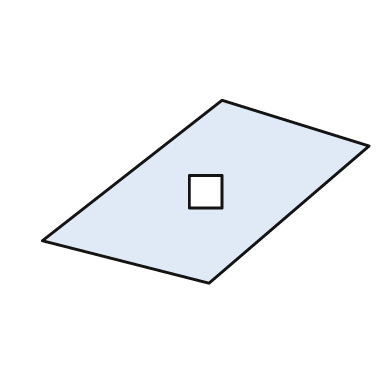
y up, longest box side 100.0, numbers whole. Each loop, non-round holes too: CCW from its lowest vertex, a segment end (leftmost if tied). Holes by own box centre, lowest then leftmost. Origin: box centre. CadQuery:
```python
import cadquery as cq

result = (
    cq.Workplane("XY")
    .moveTo(1.0, -28.0)
    .lineTo(50.0, 14.0)
    .lineTo(5.0, 28.0)
    .lineTo(-50.0, -15.0)
    .close()
    .moveTo(-5.0, -5.0)
    .lineTo(5.0, -5.0)
    .lineTo(5.0, 5.0)
    .lineTo(-5.0, 5.0)
    .close()
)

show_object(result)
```